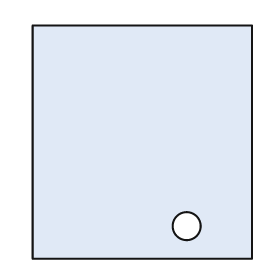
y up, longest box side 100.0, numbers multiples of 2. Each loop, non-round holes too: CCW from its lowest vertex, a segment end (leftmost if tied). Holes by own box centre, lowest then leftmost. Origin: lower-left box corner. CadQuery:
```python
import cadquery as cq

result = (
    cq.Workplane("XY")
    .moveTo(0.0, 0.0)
    .lineTo(94.0, 0.0)
    .lineTo(94.0, 100.0)
    .lineTo(0.0, 100.0)
    .close()
    .moveTo(66.0, 14.0)
    .circle(6.0)
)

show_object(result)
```